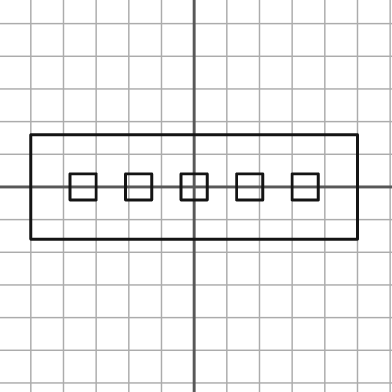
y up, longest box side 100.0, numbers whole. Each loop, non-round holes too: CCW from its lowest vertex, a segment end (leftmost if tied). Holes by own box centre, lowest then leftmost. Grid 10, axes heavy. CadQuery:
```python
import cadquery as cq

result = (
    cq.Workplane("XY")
    .moveTo(-50.0, -16.0)
    .lineTo(50.0, -16.0)
    .lineTo(50.0, 16.0)
    .lineTo(-50.0, 16.0)
    .close()
    .moveTo(-38.0, -4.0)
    .lineTo(-30.0, -4.0)
    .lineTo(-30.0, 4.0)
    .lineTo(-38.0, 4.0)
    .close()
    .moveTo(-21.0, -4.0)
    .lineTo(-13.0, -4.0)
    .lineTo(-13.0, 4.0)
    .lineTo(-21.0, 4.0)
    .close()
    .moveTo(-4.0, -4.0)
    .lineTo(4.0, -4.0)
    .lineTo(4.0, 4.0)
    .lineTo(-4.0, 4.0)
    .close()
    .moveTo(13.0, -4.0)
    .lineTo(21.0, -4.0)
    .lineTo(21.0, 4.0)
    .lineTo(13.0, 4.0)
    .close()
    .moveTo(30.0, -4.0)
    .lineTo(38.0, -4.0)
    .lineTo(38.0, 4.0)
    .lineTo(30.0, 4.0)
    .close()
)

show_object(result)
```